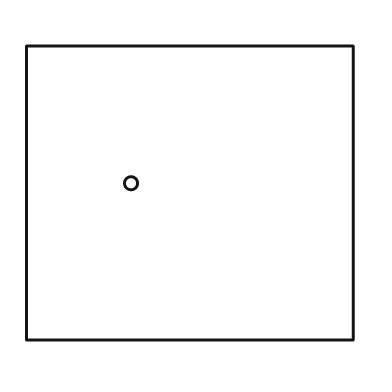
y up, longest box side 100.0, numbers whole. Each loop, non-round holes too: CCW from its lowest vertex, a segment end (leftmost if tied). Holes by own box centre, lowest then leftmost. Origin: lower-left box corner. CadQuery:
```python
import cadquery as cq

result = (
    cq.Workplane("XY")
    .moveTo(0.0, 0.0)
    .lineTo(100.0, 0.0)
    .lineTo(100.0, 90.0)
    .lineTo(0.0, 90.0)
    .close()
    .moveTo(32.0, 48.0)
    .circle(2.0)
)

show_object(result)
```